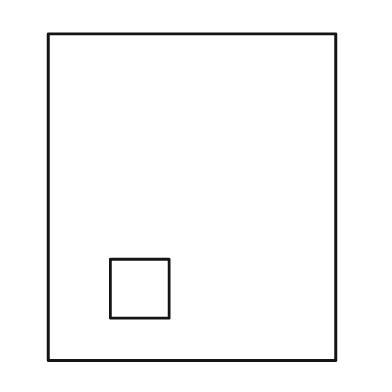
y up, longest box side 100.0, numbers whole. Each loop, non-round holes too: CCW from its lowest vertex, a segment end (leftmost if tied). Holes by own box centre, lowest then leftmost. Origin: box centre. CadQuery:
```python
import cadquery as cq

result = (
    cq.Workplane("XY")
    .moveTo(-44.0, -50.0)
    .lineTo(44.0, -50.0)
    .lineTo(44.0, 50.0)
    .lineTo(-44.0, 50.0)
    .close()
    .moveTo(-25.0, -37.0)
    .lineTo(-7.0, -37.0)
    .lineTo(-7.0, -19.0)
    .lineTo(-25.0, -19.0)
    .close()
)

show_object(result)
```